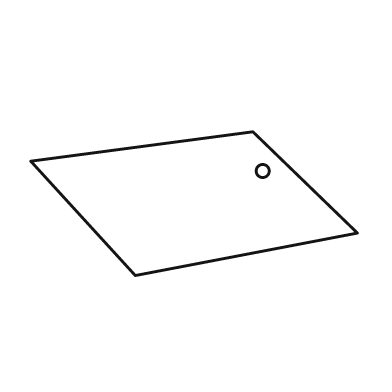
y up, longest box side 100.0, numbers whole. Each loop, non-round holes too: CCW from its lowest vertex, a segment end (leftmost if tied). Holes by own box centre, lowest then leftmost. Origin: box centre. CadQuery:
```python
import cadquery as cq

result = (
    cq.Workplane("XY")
    .moveTo(-18.0, -22.0)
    .lineTo(50.0, -9.0)
    .lineTo(18.0, 22.0)
    .lineTo(-50.0, 13.0)
    .close()
    .moveTo(21.0, 10.0)
    .circle(2.0)
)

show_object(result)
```